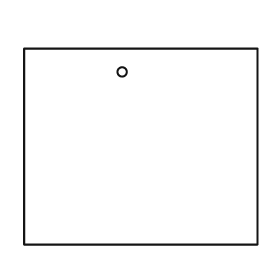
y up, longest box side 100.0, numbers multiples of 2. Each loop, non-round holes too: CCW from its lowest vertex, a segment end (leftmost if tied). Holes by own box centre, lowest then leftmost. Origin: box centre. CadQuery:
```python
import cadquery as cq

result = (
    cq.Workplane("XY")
    .moveTo(-50.0, -42.0)
    .lineTo(50.0, -42.0)
    .lineTo(50.0, 42.0)
    .lineTo(-50.0, 42.0)
    .close()
    .moveTo(-8.0, 32.0)
    .circle(2.0)
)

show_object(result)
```